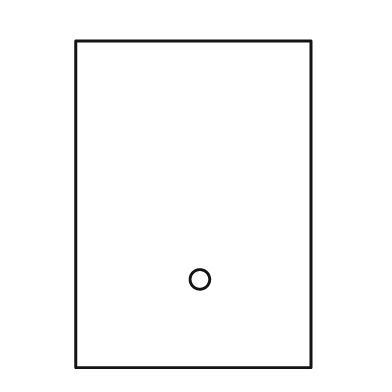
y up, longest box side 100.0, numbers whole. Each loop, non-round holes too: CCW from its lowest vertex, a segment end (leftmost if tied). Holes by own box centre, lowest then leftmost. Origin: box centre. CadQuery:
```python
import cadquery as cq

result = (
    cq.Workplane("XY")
    .moveTo(-36.0, -50.0)
    .lineTo(36.0, -50.0)
    .lineTo(36.0, 50.0)
    .lineTo(-36.0, 50.0)
    .close()
    .moveTo(2.0, -23.0)
    .circle(3.0)
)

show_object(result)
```